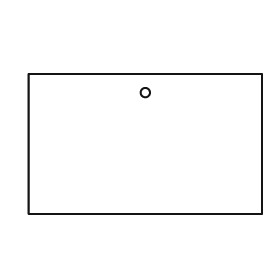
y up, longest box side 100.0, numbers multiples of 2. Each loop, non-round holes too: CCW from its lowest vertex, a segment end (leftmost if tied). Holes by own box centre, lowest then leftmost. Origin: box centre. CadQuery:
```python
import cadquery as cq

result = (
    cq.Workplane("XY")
    .moveTo(-50.0, -30.0)
    .lineTo(50.0, -30.0)
    .lineTo(50.0, 30.0)
    .lineTo(-50.0, 30.0)
    .close()
    .moveTo(0.0, 22.0)
    .circle(2.0)
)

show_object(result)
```